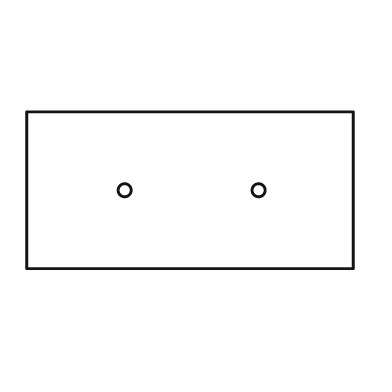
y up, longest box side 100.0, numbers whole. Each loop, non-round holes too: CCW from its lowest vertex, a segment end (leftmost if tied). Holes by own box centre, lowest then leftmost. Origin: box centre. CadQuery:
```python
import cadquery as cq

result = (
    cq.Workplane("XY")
    .moveTo(-50.0, -24.0)
    .lineTo(50.0, -24.0)
    .lineTo(50.0, 24.0)
    .lineTo(-50.0, 24.0)
    .close()
    .moveTo(-20.0, 0.0)
    .circle(2.0)
    .moveTo(21.0, 0.0)
    .circle(2.0)
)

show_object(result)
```